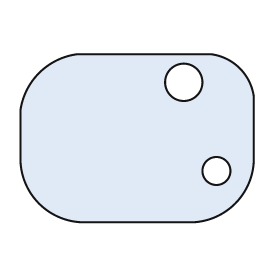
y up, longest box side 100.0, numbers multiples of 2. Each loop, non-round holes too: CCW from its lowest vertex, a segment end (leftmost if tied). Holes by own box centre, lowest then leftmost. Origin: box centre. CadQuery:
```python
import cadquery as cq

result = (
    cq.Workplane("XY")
    .moveTo(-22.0, -36.0)
    .lineTo(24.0, -36.0)
    .threePointArc((42.0, -28.0), (50.0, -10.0))
    .lineTo(50.0, 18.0)
    .threePointArc((44.0, 30.0), (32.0, 36.0))
    .lineTo(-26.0, 36.0)
    .threePointArc((-42.0, 28.0), (-50.0, 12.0))
    .lineTo(-50.0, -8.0)
    .threePointArc((-42.0, -28.0), (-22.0, -36.0))
    .close()
    .moveTo(34.0, -14.0)
    .circle(6.0)
    .moveTo(20.0, 24.0)
    .circle(8.0)
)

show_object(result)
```